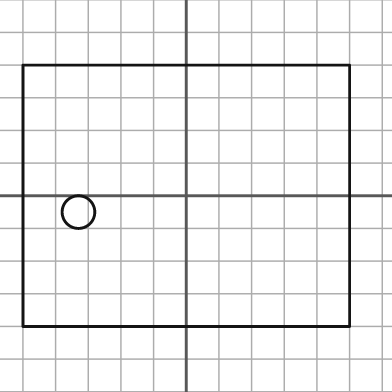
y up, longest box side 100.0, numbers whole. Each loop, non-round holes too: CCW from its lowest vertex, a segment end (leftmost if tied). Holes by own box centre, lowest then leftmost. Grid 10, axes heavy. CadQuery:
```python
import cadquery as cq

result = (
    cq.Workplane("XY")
    .moveTo(-50.0, -40.0)
    .lineTo(50.0, -40.0)
    .lineTo(50.0, 40.0)
    .lineTo(-50.0, 40.0)
    .close()
    .moveTo(-33.0, -5.0)
    .circle(5.0)
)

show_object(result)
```